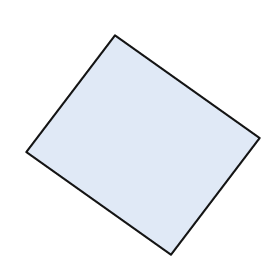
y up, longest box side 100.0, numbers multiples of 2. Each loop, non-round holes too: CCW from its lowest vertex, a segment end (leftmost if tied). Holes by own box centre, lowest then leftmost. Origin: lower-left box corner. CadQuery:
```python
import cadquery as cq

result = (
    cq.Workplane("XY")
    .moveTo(62.0, 0.0)
    .lineTo(100.0, 50.0)
    .lineTo(38.0, 94.0)
    .lineTo(0.0, 44.0)
    .close()
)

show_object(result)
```